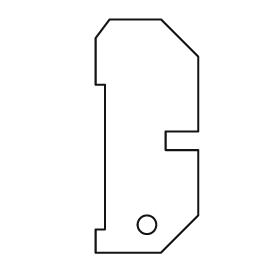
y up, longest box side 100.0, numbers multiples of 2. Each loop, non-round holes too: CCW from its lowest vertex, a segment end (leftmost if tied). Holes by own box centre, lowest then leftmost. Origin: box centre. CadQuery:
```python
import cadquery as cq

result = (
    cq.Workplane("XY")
    .moveTo(-22.0, -50.0)
    .lineTo(6.0, -50.0)
    .lineTo(22.0, -34.0)
    .lineTo(22.0, -6.0)
    .lineTo(8.0, -6.0)
    .lineTo(8.0, 2.0)
    .lineTo(22.0, 2.0)
    .lineTo(22.0, 34.0)
    .lineTo(6.0, 50.0)
    .lineTo(-16.0, 50.0)
    .lineTo(-22.0, 42.0)
    .lineTo(-22.0, 22.0)
    .lineTo(-18.0, 22.0)
    .lineTo(-18.0, -40.0)
    .lineTo(-22.0, -40.0)
    .close()
    .moveTo(0.0, -38.0)
    .circle(4.0)
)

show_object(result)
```